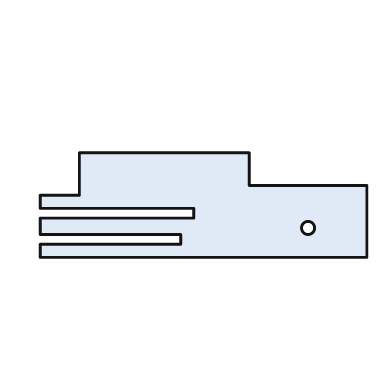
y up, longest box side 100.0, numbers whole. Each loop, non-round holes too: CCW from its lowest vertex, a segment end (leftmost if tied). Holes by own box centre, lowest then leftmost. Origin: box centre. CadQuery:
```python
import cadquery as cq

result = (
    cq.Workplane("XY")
    .moveTo(-50.0, -16.0)
    .lineTo(50.0, -16.0)
    .lineTo(50.0, 6.0)
    .lineTo(14.0, 6.0)
    .lineTo(14.0, 16.0)
    .lineTo(-38.0, 16.0)
    .lineTo(-38.0, 3.0)
    .lineTo(-50.0, 3.0)
    .lineTo(-50.0, -1.0)
    .lineTo(-3.0, -1.0)
    .lineTo(-3.0, -4.0)
    .lineTo(-50.0, -4.0)
    .lineTo(-50.0, -9.0)
    .lineTo(-7.0, -9.0)
    .lineTo(-7.0, -12.0)
    .lineTo(-50.0, -12.0)
    .close()
    .moveTo(32.0, -7.0)
    .circle(2.0)
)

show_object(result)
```